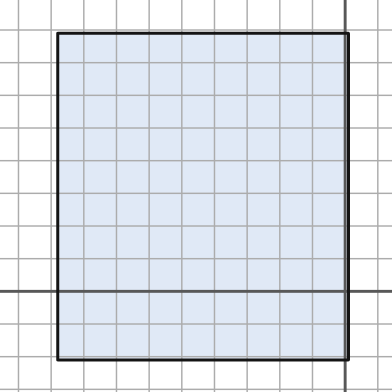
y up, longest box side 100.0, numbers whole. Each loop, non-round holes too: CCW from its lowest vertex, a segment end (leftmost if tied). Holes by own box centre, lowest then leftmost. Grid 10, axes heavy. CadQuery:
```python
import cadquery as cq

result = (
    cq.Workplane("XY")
    .moveTo(-88.0, -21.0)
    .lineTo(1.0, -21.0)
    .lineTo(1.0, 79.0)
    .lineTo(-88.0, 79.0)
    .close()
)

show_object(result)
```